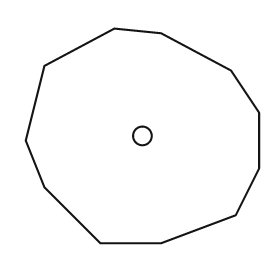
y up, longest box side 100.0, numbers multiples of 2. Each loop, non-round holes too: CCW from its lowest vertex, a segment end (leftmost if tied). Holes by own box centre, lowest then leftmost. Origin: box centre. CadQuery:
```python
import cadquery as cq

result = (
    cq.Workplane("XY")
    .moveTo(-18.0, -46.0)
    .lineTo(8.0, -46.0)
    .lineTo(40.0, -34.0)
    .lineTo(50.0, -14.0)
    .lineTo(50.0, 10.0)
    .lineTo(38.0, 28.0)
    .lineTo(8.0, 44.0)
    .lineTo(-12.0, 46.0)
    .lineTo(-42.0, 30.0)
    .lineTo(-50.0, -2.0)
    .lineTo(-42.0, -22.0)
    .close()
    .moveTo(0.0, 0.0)
    .circle(4.0)
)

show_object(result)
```